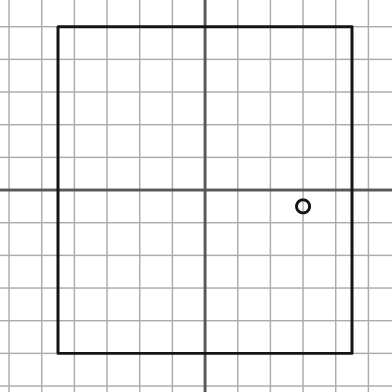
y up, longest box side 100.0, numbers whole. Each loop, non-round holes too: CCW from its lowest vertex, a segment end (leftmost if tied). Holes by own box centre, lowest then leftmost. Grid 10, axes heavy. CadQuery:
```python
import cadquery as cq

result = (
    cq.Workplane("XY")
    .moveTo(-45.0, -50.0)
    .lineTo(45.0, -50.0)
    .lineTo(45.0, 50.0)
    .lineTo(-45.0, 50.0)
    .close()
    .moveTo(30.0, -5.0)
    .circle(2.0)
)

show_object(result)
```